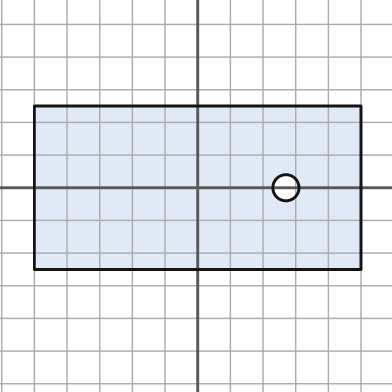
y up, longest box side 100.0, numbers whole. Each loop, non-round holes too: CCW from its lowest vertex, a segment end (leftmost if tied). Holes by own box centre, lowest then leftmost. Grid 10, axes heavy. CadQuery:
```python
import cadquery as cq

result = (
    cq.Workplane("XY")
    .moveTo(-50.0, -25.0)
    .lineTo(50.0, -25.0)
    .lineTo(50.0, 25.0)
    .lineTo(-50.0, 25.0)
    .close()
    .moveTo(27.0, 0.0)
    .circle(4.0)
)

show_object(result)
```